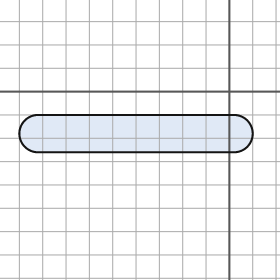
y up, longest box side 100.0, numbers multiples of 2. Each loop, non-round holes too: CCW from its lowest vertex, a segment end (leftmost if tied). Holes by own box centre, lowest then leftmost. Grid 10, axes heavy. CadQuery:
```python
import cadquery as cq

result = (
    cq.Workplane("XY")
    .moveTo(-82.0, -26.0)
    .lineTo(2.0, -26.0)
    .threePointArc((10.0, -18.0), (2.0, -10.0))
    .lineTo(-82.0, -10.0)
    .threePointArc((-90.0, -18.0), (-82.0, -26.0))
    .close()
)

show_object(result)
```